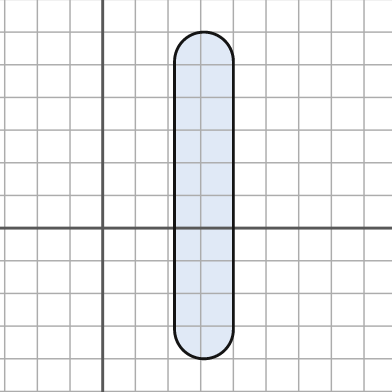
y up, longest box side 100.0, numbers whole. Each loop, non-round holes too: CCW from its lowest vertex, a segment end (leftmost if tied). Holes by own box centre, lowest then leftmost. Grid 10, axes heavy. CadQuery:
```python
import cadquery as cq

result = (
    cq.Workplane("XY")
    .moveTo(22.0, -31.0)
    .threePointArc((31.0, -40.0), (40.0, -31.0))
    .lineTo(40.0, 51.0)
    .threePointArc((31.0, 60.0), (22.0, 51.0))
    .close()
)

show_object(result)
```